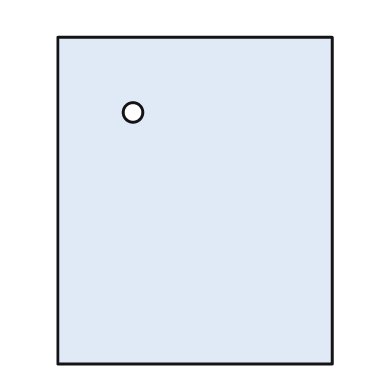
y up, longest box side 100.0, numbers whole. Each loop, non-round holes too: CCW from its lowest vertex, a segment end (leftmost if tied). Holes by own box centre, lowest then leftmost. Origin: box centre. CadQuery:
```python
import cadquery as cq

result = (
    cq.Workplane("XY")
    .moveTo(-42.0, -50.0)
    .lineTo(42.0, -50.0)
    .lineTo(42.0, 50.0)
    .lineTo(-42.0, 50.0)
    .close()
    .moveTo(-19.0, 27.0)
    .circle(3.0)
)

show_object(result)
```